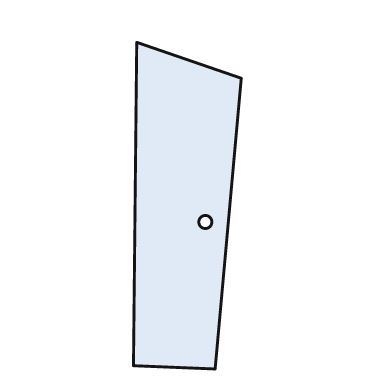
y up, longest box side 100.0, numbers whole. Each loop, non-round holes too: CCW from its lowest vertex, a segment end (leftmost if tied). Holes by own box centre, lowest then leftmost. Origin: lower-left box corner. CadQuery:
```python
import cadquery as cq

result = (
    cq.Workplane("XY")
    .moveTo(25.0, 0.0)
    .lineTo(33.0, 89.0)
    .lineTo(1.0, 100.0)
    .lineTo(0.0, 1.0)
    .close()
    .moveTo(22.0, 45.0)
    .circle(2.0)
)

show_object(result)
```